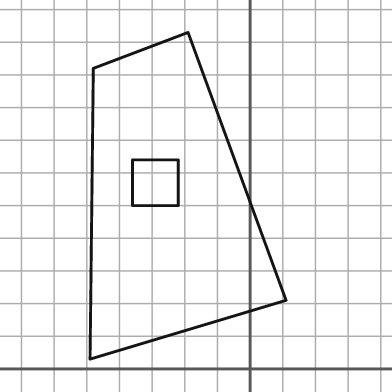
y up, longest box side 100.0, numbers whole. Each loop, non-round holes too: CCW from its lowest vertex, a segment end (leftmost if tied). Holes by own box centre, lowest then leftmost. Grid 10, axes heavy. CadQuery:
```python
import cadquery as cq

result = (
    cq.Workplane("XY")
    .moveTo(-49.0, 3.0)
    .lineTo(11.0, 21.0)
    .lineTo(-19.0, 103.0)
    .lineTo(-48.0, 92.0)
    .close()
    .moveTo(-36.0, 50.0)
    .lineTo(-22.0, 50.0)
    .lineTo(-22.0, 64.0)
    .lineTo(-36.0, 64.0)
    .close()
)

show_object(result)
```